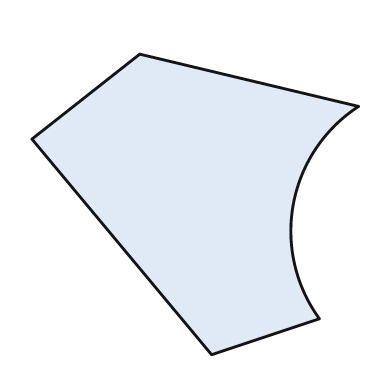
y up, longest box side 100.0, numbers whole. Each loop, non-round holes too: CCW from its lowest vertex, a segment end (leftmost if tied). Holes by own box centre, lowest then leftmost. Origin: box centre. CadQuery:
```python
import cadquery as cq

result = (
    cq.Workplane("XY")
    .moveTo(5.0, -46.0)
    .lineTo(38.0, -35.0)
    .threePointArc((30.0, 0.0), (50.0, 30.0))
    .lineTo(-17.0, 46.0)
    .lineTo(-50.0, 20.0)
    .close()
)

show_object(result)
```